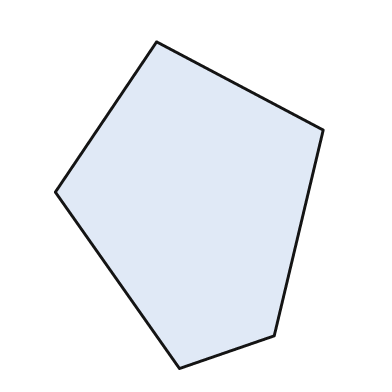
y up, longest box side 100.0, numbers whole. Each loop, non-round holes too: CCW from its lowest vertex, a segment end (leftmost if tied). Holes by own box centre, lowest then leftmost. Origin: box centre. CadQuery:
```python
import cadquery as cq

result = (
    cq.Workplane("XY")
    .moveTo(-3.0, -50.0)
    .lineTo(26.0, -40.0)
    .lineTo(41.0, 23.0)
    .lineTo(-10.0, 50.0)
    .lineTo(-41.0, 4.0)
    .close()
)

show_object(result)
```